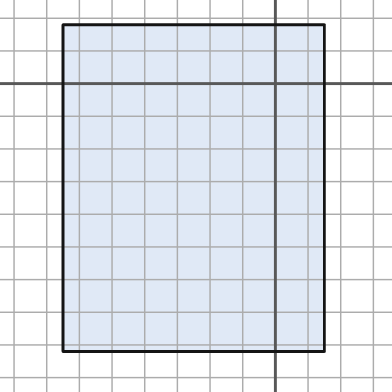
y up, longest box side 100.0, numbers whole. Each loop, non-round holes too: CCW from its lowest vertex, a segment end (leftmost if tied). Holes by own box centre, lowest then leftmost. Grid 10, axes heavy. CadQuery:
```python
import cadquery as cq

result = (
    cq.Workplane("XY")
    .moveTo(-65.0, -82.0)
    .lineTo(15.0, -82.0)
    .lineTo(15.0, 18.0)
    .lineTo(-65.0, 18.0)
    .close()
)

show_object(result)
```